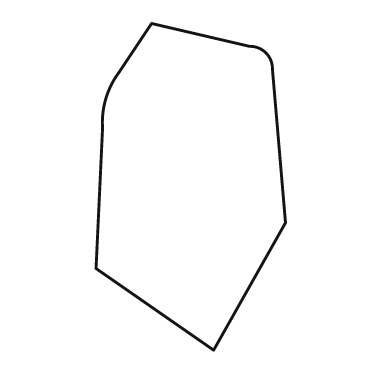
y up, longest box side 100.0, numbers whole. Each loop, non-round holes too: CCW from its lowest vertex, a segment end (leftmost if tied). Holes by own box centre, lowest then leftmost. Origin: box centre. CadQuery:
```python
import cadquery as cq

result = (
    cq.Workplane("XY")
    .moveTo(7.0, -50.0)
    .lineTo(29.0, -11.0)
    .lineTo(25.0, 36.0)
    .threePointArc((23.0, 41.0), (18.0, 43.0))
    .lineTo(-12.0, 50.0)
    .lineTo(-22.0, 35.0)
    .threePointArc((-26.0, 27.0), (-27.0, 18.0))
    .lineTo(-29.0, -25.0)
    .close()
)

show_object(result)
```